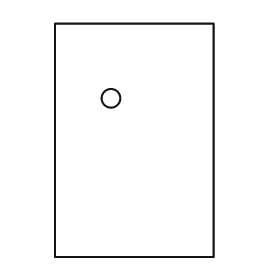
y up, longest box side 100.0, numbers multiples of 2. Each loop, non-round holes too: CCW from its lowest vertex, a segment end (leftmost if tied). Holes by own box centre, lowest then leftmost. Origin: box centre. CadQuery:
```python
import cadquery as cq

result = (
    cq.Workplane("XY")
    .moveTo(-34.0, -50.0)
    .lineTo(34.0, -50.0)
    .lineTo(34.0, 50.0)
    .lineTo(-34.0, 50.0)
    .close()
    .moveTo(-10.0, 18.0)
    .circle(4.0)
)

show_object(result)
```